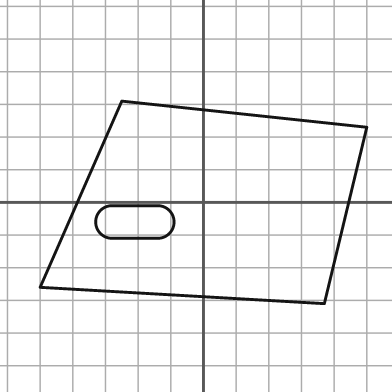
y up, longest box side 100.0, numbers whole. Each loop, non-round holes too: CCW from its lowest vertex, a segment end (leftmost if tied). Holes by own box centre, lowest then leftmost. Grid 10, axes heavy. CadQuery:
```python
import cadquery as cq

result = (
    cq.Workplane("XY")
    .moveTo(37.0, -31.0)
    .lineTo(50.0, 23.0)
    .lineTo(-25.0, 31.0)
    .lineTo(-50.0, -26.0)
    .close()
    .moveTo(-28.0, -11.0)
    .lineTo(-14.0, -11.0)
    .threePointArc((-9.0, -6.0), (-14.0, -1.0))
    .lineTo(-28.0, -1.0)
    .threePointArc((-33.0, -6.0), (-28.0, -11.0))
    .close()
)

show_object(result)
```